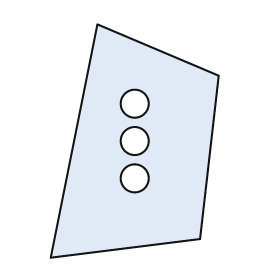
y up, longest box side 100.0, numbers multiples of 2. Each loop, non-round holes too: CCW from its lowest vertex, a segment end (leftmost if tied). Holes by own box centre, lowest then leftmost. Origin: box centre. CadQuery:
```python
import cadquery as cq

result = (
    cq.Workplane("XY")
    .moveTo(-36.0, -50.0)
    .lineTo(28.0, -42.0)
    .lineTo(36.0, 28.0)
    .lineTo(-16.0, 50.0)
    .close()
    .moveTo(0.0, -16.0)
    .circle(6.0)
    .moveTo(0.0, 0.0)
    .circle(6.0)
    .moveTo(0.0, 16.0)
    .circle(6.0)
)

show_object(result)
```